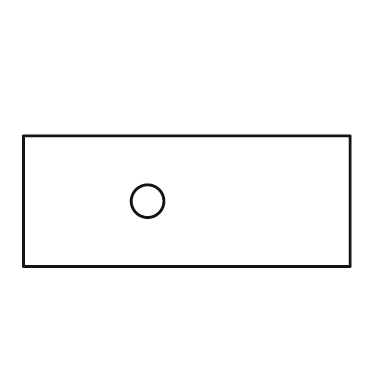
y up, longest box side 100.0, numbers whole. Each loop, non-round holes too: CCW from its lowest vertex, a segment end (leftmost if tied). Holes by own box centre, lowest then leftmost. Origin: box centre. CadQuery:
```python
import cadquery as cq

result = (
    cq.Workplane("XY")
    .moveTo(-50.0, -20.0)
    .lineTo(50.0, -20.0)
    .lineTo(50.0, 20.0)
    .lineTo(-50.0, 20.0)
    .close()
    .moveTo(-12.0, 0.0)
    .circle(5.0)
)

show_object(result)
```